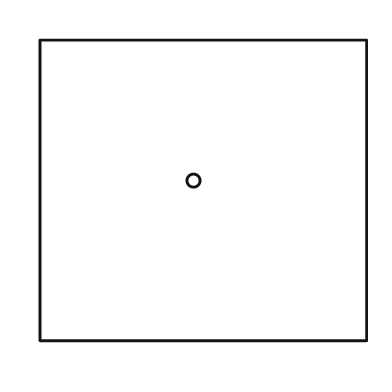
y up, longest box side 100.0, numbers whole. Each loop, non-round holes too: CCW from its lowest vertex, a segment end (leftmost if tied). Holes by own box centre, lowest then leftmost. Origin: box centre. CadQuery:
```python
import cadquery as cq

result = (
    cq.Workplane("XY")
    .moveTo(-50.0, -46.0)
    .lineTo(50.0, -46.0)
    .lineTo(50.0, 46.0)
    .lineTo(-50.0, 46.0)
    .close()
    .moveTo(-3.0, 3.0)
    .circle(2.0)
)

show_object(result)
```